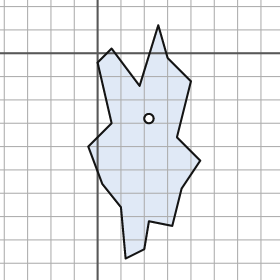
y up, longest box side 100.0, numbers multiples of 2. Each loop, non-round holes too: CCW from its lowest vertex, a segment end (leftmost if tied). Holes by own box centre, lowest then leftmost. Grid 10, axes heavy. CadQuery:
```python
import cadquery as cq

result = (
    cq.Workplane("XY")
    .moveTo(12.0, -88.0)
    .lineTo(20.0, -84.0)
    .lineTo(22.0, -72.0)
    .lineTo(32.0, -74.0)
    .lineTo(36.0, -58.0)
    .lineTo(44.0, -46.0)
    .lineTo(34.0, -36.0)
    .lineTo(40.0, -12.0)
    .lineTo(30.0, -2.0)
    .lineTo(26.0, 12.0)
    .lineTo(18.0, -14.0)
    .lineTo(6.0, 2.0)
    .lineTo(0.0, -4.0)
    .lineTo(6.0, -30.0)
    .lineTo(-4.0, -40.0)
    .lineTo(2.0, -56.0)
    .lineTo(10.0, -66.0)
    .close()
    .moveTo(22.0, -28.0)
    .circle(2.0)
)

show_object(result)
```